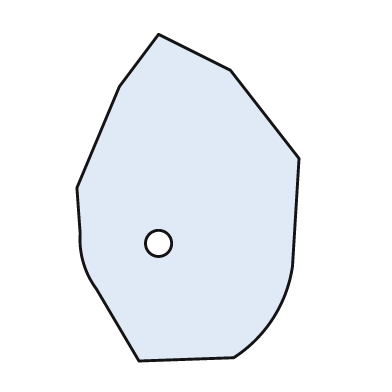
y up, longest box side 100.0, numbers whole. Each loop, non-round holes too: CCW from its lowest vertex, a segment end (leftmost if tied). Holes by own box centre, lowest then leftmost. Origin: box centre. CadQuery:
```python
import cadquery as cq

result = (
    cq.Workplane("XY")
    .moveTo(-15.0, -50.0)
    .lineTo(14.0, -49.0)
    .threePointArc((26.0, -37.0), (32.0, -21.0))
    .lineTo(34.0, 12.0)
    .lineTo(13.0, 39.0)
    .lineTo(-9.0, 50.0)
    .lineTo(-21.0, 34.0)
    .lineTo(-34.0, 3.0)
    .lineTo(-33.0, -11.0)
    .threePointArc((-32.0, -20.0), (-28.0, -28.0))
    .close()
    .moveTo(-9.0, -14.0)
    .circle(4.0)
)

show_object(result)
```